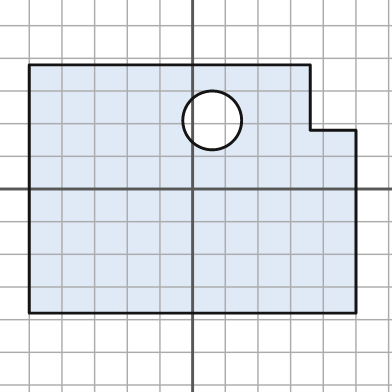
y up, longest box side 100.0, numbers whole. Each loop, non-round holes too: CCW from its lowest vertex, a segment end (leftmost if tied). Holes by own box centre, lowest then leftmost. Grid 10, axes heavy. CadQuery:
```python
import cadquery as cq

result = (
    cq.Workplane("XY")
    .moveTo(-50.0, -38.0)
    .lineTo(50.0, -38.0)
    .lineTo(50.0, 18.0)
    .lineTo(36.0, 18.0)
    .lineTo(36.0, 38.0)
    .lineTo(-50.0, 38.0)
    .close()
    .moveTo(6.0, 21.0)
    .circle(9.0)
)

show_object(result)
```